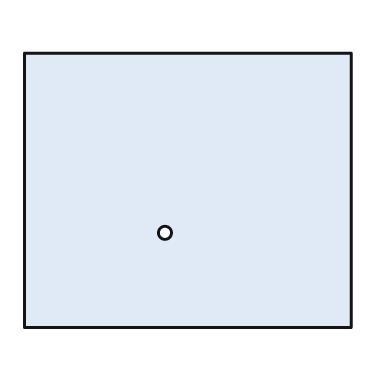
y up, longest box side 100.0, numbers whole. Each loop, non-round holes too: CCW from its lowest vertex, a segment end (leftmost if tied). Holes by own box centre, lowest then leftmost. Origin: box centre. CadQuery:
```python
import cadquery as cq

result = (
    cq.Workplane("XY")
    .moveTo(-50.0, -42.0)
    .lineTo(50.0, -42.0)
    .lineTo(50.0, 42.0)
    .lineTo(-50.0, 42.0)
    .close()
    .moveTo(-7.0, -13.0)
    .circle(2.0)
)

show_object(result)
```